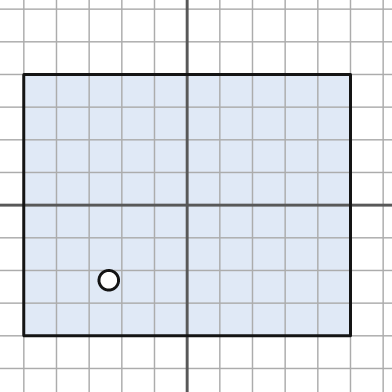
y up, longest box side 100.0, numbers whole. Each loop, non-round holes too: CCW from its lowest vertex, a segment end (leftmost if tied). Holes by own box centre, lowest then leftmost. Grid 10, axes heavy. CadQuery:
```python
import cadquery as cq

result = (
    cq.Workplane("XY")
    .moveTo(-50.0, -40.0)
    .lineTo(50.0, -40.0)
    .lineTo(50.0, 40.0)
    .lineTo(-50.0, 40.0)
    .close()
    .moveTo(-24.0, -23.0)
    .circle(3.0)
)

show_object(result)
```